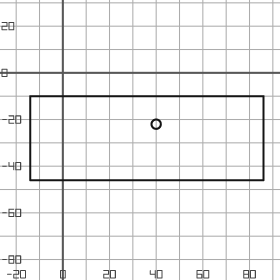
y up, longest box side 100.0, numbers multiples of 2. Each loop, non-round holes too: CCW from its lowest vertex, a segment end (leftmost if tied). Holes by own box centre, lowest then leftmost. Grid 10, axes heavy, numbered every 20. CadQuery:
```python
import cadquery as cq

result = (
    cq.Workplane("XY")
    .moveTo(-14.0, -46.0)
    .lineTo(86.0, -46.0)
    .lineTo(86.0, -10.0)
    .lineTo(-14.0, -10.0)
    .close()
    .moveTo(40.0, -22.0)
    .circle(2.0)
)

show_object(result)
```